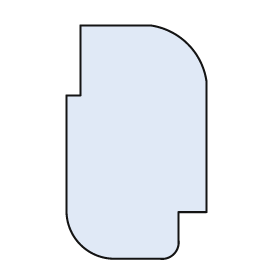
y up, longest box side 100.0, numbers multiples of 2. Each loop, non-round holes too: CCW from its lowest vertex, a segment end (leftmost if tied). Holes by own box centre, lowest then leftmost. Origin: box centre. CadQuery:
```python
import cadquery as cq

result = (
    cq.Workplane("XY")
    .moveTo(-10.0, -50.0)
    .lineTo(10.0, -50.0)
    .threePointArc((16.0, -48.0), (18.0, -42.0))
    .lineTo(18.0, -30.0)
    .lineTo(30.0, -30.0)
    .lineTo(30.0, 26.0)
    .threePointArc((22.0, 42.0), (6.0, 50.0))
    .lineTo(-24.0, 50.0)
    .lineTo(-24.0, 20.0)
    .lineTo(-30.0, 20.0)
    .lineTo(-30.0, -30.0)
    .threePointArc((-24.0, -44.0), (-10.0, -50.0))
    .close()
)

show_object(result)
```